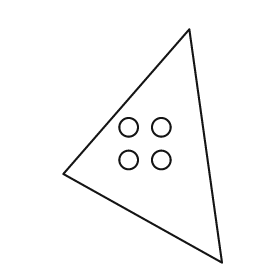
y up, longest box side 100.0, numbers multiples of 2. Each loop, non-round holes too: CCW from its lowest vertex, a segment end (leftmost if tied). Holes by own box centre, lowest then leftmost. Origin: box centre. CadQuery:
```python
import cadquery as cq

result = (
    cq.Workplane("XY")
    .moveTo(34.0, -50.0)
    .lineTo(20.0, 50.0)
    .lineTo(-34.0, -12.0)
    .close()
    .moveTo(-6.0, -6.0)
    .circle(4.0)
    .moveTo(8.0, -6.0)
    .circle(4.0)
    .moveTo(-6.0, 8.0)
    .circle(4.0)
    .moveTo(8.0, 8.0)
    .circle(4.0)
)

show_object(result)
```